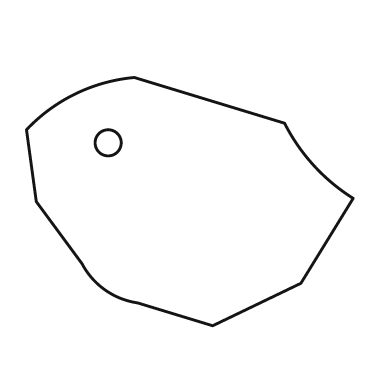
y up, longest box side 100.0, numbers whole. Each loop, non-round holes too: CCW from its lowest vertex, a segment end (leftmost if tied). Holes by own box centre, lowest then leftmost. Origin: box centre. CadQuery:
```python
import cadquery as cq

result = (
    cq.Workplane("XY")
    .moveTo(7.0, -38.0)
    .lineTo(34.0, -25.0)
    .lineTo(50.0, 1.0)
    .threePointArc((38.0, 11.0), (29.0, 24.0))
    .lineTo(-17.0, 38.0)
    .threePointArc((-35.0, 33.0), (-50.0, 22.0))
    .lineTo(-47.0, 0.0)
    .lineTo(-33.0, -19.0)
    .threePointArc((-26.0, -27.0), (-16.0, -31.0))
    .close()
    .moveTo(-25.0, 18.0)
    .circle(4.0)
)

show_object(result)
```